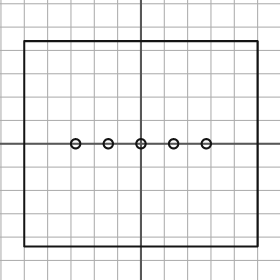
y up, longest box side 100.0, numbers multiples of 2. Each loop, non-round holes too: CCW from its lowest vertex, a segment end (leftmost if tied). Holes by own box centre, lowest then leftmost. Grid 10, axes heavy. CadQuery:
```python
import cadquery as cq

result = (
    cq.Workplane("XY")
    .moveTo(-50.0, -44.0)
    .lineTo(50.0, -44.0)
    .lineTo(50.0, 44.0)
    .lineTo(-50.0, 44.0)
    .close()
    .moveTo(-28.0, 0.0)
    .circle(2.0)
    .moveTo(-14.0, 0.0)
    .circle(2.0)
    .moveTo(0.0, 0.0)
    .circle(2.0)
    .moveTo(14.0, 0.0)
    .circle(2.0)
    .moveTo(28.0, 0.0)
    .circle(2.0)
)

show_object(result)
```